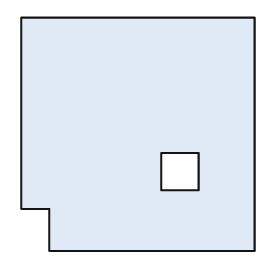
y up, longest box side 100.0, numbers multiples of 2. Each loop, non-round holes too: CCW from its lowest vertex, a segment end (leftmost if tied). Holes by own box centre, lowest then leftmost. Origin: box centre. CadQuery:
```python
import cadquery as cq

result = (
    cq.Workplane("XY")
    .moveTo(-38.0, -50.0)
    .lineTo(50.0, -50.0)
    .lineTo(50.0, 50.0)
    .lineTo(-50.0, 50.0)
    .lineTo(-50.0, -32.0)
    .lineTo(-38.0, -32.0)
    .close()
    .moveTo(10.0, -24.0)
    .lineTo(26.0, -24.0)
    .lineTo(26.0, -8.0)
    .lineTo(10.0, -8.0)
    .close()
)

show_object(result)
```